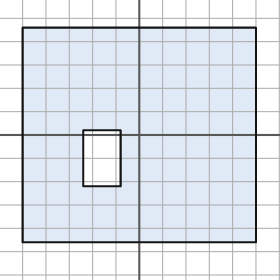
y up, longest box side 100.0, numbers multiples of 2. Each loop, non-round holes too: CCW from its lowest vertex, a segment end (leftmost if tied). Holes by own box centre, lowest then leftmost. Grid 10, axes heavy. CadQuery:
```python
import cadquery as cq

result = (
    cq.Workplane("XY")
    .moveTo(-50.0, -46.0)
    .lineTo(50.0, -46.0)
    .lineTo(50.0, 46.0)
    .lineTo(-50.0, 46.0)
    .close()
    .moveTo(-24.0, -22.0)
    .lineTo(-8.0, -22.0)
    .lineTo(-8.0, 2.0)
    .lineTo(-24.0, 2.0)
    .close()
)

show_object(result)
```